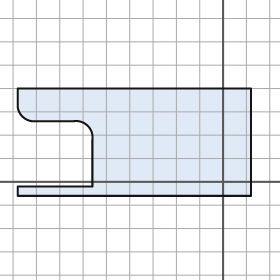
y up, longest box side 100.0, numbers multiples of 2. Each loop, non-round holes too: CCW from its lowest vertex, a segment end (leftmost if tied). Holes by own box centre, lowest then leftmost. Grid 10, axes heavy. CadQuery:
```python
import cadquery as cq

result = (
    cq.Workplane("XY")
    .moveTo(-88.0, -6.0)
    .lineTo(12.0, -6.0)
    .lineTo(12.0, 40.0)
    .lineTo(-88.0, 40.0)
    .lineTo(-88.0, 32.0)
    .threePointArc((-86.0, 28.0), (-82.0, 26.0))
    .lineTo(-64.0, 26.0)
    .threePointArc((-58.0, 24.0), (-56.0, 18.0))
    .lineTo(-56.0, -2.0)
    .lineTo(-88.0, -2.0)
    .close()
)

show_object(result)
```